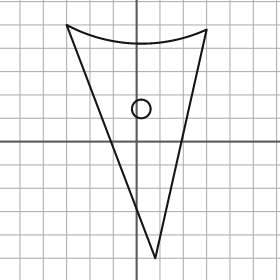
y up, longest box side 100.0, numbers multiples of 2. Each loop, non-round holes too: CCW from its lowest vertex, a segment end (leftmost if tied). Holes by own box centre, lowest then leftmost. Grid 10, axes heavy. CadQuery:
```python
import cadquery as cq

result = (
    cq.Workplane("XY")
    .moveTo(8.0, -50.0)
    .lineTo(30.0, 48.0)
    .threePointArc((0.0, 42.0), (-30.0, 50.0))
    .close()
    .moveTo(2.0, 14.0)
    .circle(4.0)
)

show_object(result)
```